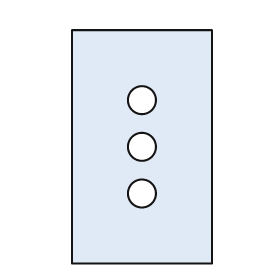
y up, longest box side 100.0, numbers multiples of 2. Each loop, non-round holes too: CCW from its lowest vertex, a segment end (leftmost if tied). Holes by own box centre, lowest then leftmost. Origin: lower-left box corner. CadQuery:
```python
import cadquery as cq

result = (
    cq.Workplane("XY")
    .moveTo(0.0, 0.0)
    .lineTo(60.0, 0.0)
    .lineTo(60.0, 100.0)
    .lineTo(0.0, 100.0)
    .close()
    .moveTo(30.0, 30.0)
    .circle(6.0)
    .moveTo(30.0, 50.0)
    .circle(6.0)
    .moveTo(30.0, 70.0)
    .circle(6.0)
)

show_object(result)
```